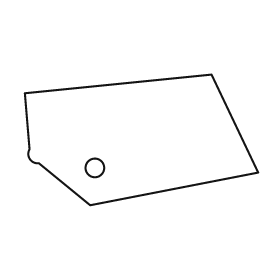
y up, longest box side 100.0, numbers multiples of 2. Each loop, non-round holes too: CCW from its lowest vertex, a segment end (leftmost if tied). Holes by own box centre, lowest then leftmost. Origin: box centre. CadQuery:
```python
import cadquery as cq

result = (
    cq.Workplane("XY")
    .moveTo(-22.0, -28.0)
    .lineTo(50.0, -14.0)
    .lineTo(30.0, 28.0)
    .lineTo(-50.0, 20.0)
    .lineTo(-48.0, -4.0)
    .threePointArc((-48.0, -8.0), (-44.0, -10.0))
    .close()
    .moveTo(-20.0, -12.0)
    .circle(4.0)
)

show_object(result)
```